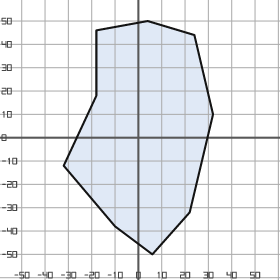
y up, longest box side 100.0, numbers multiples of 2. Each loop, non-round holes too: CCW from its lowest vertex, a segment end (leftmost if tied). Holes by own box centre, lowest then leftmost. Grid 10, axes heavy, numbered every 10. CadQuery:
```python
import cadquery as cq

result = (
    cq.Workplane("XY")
    .moveTo(6.0, -50.0)
    .lineTo(22.0, -32.0)
    .lineTo(32.0, 10.0)
    .lineTo(24.0, 44.0)
    .lineTo(4.0, 50.0)
    .lineTo(-18.0, 46.0)
    .lineTo(-18.0, 18.0)
    .lineTo(-32.0, -12.0)
    .lineTo(-10.0, -38.0)
    .close()
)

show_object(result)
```